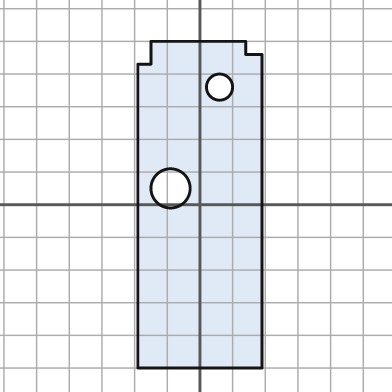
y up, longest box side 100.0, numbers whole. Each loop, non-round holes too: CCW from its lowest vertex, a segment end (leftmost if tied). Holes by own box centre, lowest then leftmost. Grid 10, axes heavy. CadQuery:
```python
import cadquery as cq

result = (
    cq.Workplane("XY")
    .moveTo(-19.0, -50.0)
    .lineTo(19.0, -50.0)
    .lineTo(19.0, 46.0)
    .lineTo(14.0, 46.0)
    .lineTo(14.0, 50.0)
    .lineTo(-15.0, 50.0)
    .lineTo(-15.0, 43.0)
    .lineTo(-19.0, 43.0)
    .close()
    .moveTo(-9.0, 5.0)
    .circle(6.0)
    .moveTo(6.0, 36.0)
    .circle(4.0)
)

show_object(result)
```